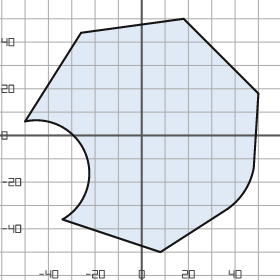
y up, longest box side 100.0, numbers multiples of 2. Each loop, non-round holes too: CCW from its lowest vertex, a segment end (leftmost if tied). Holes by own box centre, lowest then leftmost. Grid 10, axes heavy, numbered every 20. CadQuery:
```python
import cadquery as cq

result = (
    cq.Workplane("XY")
    .moveTo(8.0, -50.0)
    .lineTo(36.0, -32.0)
    .threePointArc((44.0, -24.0), (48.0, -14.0))
    .lineTo(50.0, 18.0)
    .lineTo(18.0, 50.0)
    .lineTo(-26.0, 44.0)
    .lineTo(-50.0, 6.0)
    .threePointArc((-24.0, -8.0), (-34.0, -36.0))
    .close()
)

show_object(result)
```